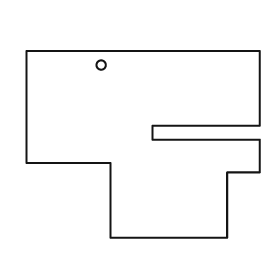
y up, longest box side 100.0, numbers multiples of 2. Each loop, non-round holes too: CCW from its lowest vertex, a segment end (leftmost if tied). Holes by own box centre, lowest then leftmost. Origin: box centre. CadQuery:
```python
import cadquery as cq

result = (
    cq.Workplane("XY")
    .moveTo(-14.0, -40.0)
    .lineTo(36.0, -40.0)
    .lineTo(36.0, -12.0)
    .lineTo(50.0, -12.0)
    .lineTo(50.0, 2.0)
    .lineTo(4.0, 2.0)
    .lineTo(4.0, 8.0)
    .lineTo(50.0, 8.0)
    .lineTo(50.0, 40.0)
    .lineTo(-50.0, 40.0)
    .lineTo(-50.0, -8.0)
    .lineTo(-14.0, -8.0)
    .close()
    .moveTo(-18.0, 34.0)
    .circle(2.0)
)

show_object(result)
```